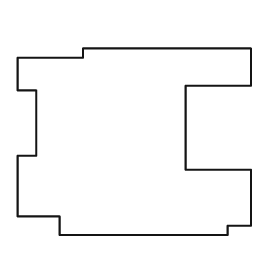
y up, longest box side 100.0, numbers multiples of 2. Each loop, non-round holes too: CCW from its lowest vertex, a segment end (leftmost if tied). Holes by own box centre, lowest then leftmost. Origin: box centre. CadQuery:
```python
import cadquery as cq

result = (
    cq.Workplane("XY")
    .moveTo(-32.0, -40.0)
    .lineTo(40.0, -40.0)
    .lineTo(40.0, -36.0)
    .lineTo(50.0, -36.0)
    .lineTo(50.0, -12.0)
    .lineTo(22.0, -12.0)
    .lineTo(22.0, 24.0)
    .lineTo(50.0, 24.0)
    .lineTo(50.0, 40.0)
    .lineTo(-22.0, 40.0)
    .lineTo(-22.0, 36.0)
    .lineTo(-50.0, 36.0)
    .lineTo(-50.0, 22.0)
    .lineTo(-42.0, 22.0)
    .lineTo(-42.0, -6.0)
    .lineTo(-50.0, -6.0)
    .lineTo(-50.0, -32.0)
    .lineTo(-32.0, -32.0)
    .close()
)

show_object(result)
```